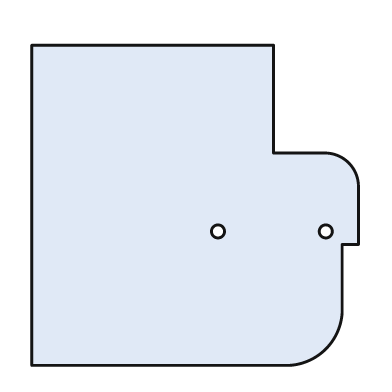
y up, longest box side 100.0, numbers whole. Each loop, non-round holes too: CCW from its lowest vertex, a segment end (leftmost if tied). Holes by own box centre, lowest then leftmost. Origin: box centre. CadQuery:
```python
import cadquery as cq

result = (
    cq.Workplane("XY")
    .moveTo(-50.0, -49.0)
    .lineTo(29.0, -49.0)
    .threePointArc((40.0, -44.0), (45.0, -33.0))
    .lineTo(45.0, -12.0)
    .lineTo(50.0, -12.0)
    .lineTo(50.0, 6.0)
    .threePointArc((47.0, 13.0), (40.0, 16.0))
    .lineTo(24.0, 16.0)
    .lineTo(24.0, 49.0)
    .lineTo(-50.0, 49.0)
    .close()
    .moveTo(7.0, -8.0)
    .circle(2.0)
    .moveTo(40.0, -8.0)
    .circle(2.0)
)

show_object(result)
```